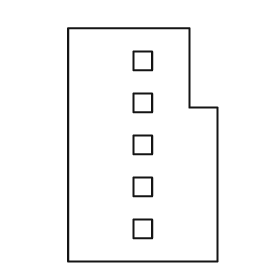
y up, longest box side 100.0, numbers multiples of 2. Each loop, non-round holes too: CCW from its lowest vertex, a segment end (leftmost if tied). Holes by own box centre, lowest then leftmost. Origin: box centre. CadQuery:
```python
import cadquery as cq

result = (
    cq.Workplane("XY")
    .moveTo(-32.0, -50.0)
    .lineTo(32.0, -50.0)
    .lineTo(32.0, 16.0)
    .lineTo(20.0, 16.0)
    .lineTo(20.0, 50.0)
    .lineTo(-32.0, 50.0)
    .close()
    .moveTo(-4.0, -40.0)
    .lineTo(4.0, -40.0)
    .lineTo(4.0, -32.0)
    .lineTo(-4.0, -32.0)
    .close()
    .moveTo(-4.0, -22.0)
    .lineTo(4.0, -22.0)
    .lineTo(4.0, -14.0)
    .lineTo(-4.0, -14.0)
    .close()
    .moveTo(-4.0, -4.0)
    .lineTo(4.0, -4.0)
    .lineTo(4.0, 4.0)
    .lineTo(-4.0, 4.0)
    .close()
    .moveTo(-4.0, 14.0)
    .lineTo(4.0, 14.0)
    .lineTo(4.0, 22.0)
    .lineTo(-4.0, 22.0)
    .close()
    .moveTo(-4.0, 32.0)
    .lineTo(4.0, 32.0)
    .lineTo(4.0, 40.0)
    .lineTo(-4.0, 40.0)
    .close()
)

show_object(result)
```